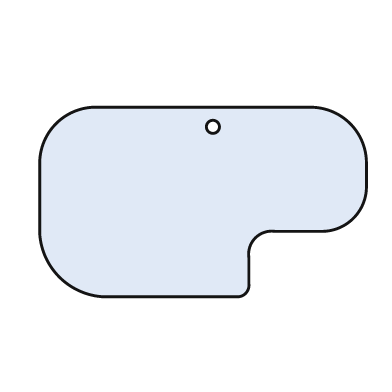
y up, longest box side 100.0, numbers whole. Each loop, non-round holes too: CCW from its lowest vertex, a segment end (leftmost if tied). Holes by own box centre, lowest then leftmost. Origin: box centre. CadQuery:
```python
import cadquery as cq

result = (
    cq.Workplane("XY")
    .moveTo(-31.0, -29.0)
    .lineTo(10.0, -29.0)
    .threePointArc((13.0, -28.0), (14.0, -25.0))
    .lineTo(14.0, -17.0)
    .threePointArc((16.0, -11.0), (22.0, -9.0))
    .lineTo(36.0, -9.0)
    .threePointArc((46.0, -5.0), (50.0, 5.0))
    .lineTo(50.0, 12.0)
    .threePointArc((45.0, 24.0), (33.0, 29.0))
    .lineTo(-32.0, 29.0)
    .threePointArc((-45.0, 24.0), (-50.0, 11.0))
    .lineTo(-50.0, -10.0)
    .threePointArc((-44.0, -23.0), (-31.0, -29.0))
    .close()
    .moveTo(3.0, 23.0)
    .circle(2.0)
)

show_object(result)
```